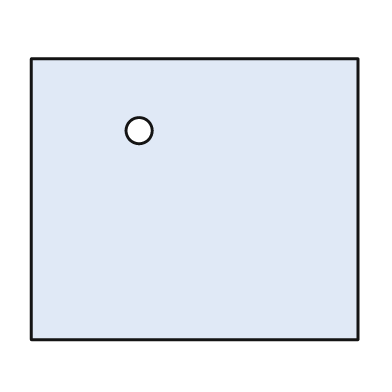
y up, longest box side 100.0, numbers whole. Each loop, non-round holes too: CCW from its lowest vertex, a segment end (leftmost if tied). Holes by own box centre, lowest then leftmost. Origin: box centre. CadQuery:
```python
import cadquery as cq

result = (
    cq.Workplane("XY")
    .moveTo(-50.0, -43.0)
    .lineTo(50.0, -43.0)
    .lineTo(50.0, 43.0)
    .lineTo(-50.0, 43.0)
    .close()
    .moveTo(-17.0, 21.0)
    .circle(4.0)
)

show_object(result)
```